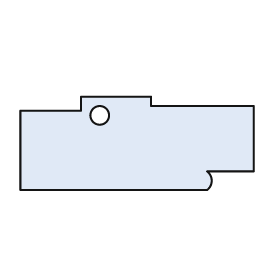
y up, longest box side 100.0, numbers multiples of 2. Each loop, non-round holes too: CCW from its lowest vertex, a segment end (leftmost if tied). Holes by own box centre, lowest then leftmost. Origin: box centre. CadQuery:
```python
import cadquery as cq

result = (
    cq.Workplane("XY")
    .moveTo(-50.0, -20.0)
    .lineTo(30.0, -20.0)
    .threePointArc((32.0, -16.0), (30.0, -12.0))
    .lineTo(50.0, -12.0)
    .lineTo(50.0, 16.0)
    .lineTo(6.0, 16.0)
    .lineTo(6.0, 20.0)
    .lineTo(-24.0, 20.0)
    .lineTo(-24.0, 14.0)
    .lineTo(-50.0, 14.0)
    .close()
    .moveTo(-16.0, 12.0)
    .circle(4.0)
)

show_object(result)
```